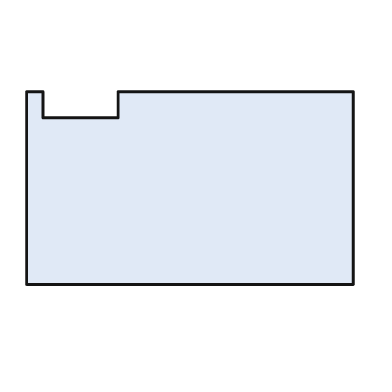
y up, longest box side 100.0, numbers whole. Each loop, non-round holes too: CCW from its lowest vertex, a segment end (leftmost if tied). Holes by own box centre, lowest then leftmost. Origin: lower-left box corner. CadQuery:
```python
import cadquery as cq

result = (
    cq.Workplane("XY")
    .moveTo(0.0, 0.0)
    .lineTo(100.0, 0.0)
    .lineTo(100.0, 59.0)
    .lineTo(28.0, 59.0)
    .lineTo(28.0, 51.0)
    .lineTo(5.0, 51.0)
    .lineTo(5.0, 59.0)
    .lineTo(0.0, 59.0)
    .close()
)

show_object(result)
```